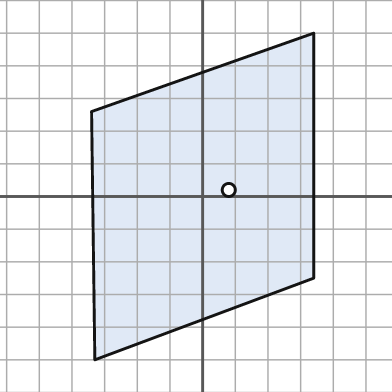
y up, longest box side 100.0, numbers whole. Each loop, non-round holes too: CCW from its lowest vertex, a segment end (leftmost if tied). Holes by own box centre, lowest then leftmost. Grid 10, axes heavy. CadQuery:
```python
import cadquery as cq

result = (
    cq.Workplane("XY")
    .moveTo(-33.0, -50.0)
    .lineTo(34.0, -25.0)
    .lineTo(34.0, 50.0)
    .lineTo(-34.0, 26.0)
    .close()
    .moveTo(8.0, 2.0)
    .circle(2.0)
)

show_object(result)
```